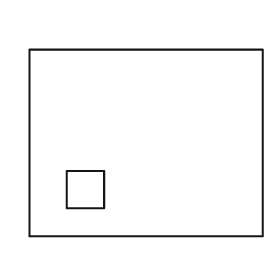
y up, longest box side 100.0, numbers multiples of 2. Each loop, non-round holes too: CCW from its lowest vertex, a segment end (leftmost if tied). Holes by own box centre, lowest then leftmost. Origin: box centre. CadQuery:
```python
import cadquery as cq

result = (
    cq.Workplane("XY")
    .moveTo(-50.0, -40.0)
    .lineTo(50.0, -40.0)
    .lineTo(50.0, 40.0)
    .lineTo(-50.0, 40.0)
    .close()
    .moveTo(-34.0, -28.0)
    .lineTo(-18.0, -28.0)
    .lineTo(-18.0, -12.0)
    .lineTo(-34.0, -12.0)
    .close()
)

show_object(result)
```